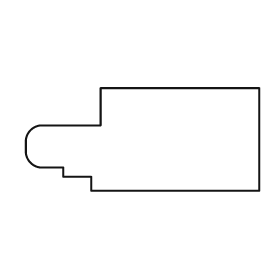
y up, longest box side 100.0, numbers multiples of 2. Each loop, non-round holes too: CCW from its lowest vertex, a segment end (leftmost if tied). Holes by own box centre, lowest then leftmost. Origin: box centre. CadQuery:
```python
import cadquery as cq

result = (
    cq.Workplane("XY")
    .moveTo(-22.0, -22.0)
    .lineTo(50.0, -22.0)
    .lineTo(50.0, 22.0)
    .lineTo(-18.0, 22.0)
    .lineTo(-18.0, 6.0)
    .lineTo(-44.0, 6.0)
    .threePointArc((-48.0, 4.0), (-50.0, 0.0))
    .lineTo(-50.0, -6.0)
    .threePointArc((-48.0, -10.0), (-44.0, -12.0))
    .lineTo(-34.0, -12.0)
    .lineTo(-34.0, -16.0)
    .lineTo(-22.0, -16.0)
    .close()
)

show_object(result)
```